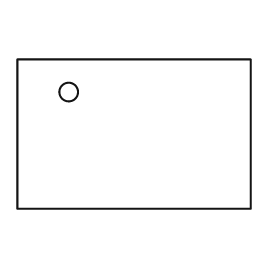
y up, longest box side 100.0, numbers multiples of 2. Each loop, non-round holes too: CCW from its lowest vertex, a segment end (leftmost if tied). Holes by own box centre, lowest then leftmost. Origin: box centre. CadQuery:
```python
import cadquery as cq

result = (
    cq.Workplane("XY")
    .moveTo(-50.0, -32.0)
    .lineTo(50.0, -32.0)
    .lineTo(50.0, 32.0)
    .lineTo(-50.0, 32.0)
    .close()
    .moveTo(-28.0, 18.0)
    .circle(4.0)
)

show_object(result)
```